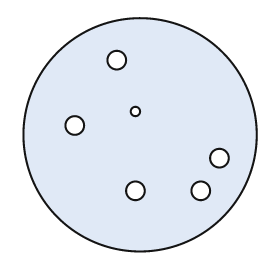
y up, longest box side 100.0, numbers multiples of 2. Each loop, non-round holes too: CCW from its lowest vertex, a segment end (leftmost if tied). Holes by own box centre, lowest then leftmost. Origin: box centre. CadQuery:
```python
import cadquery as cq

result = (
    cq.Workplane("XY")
    .moveTo(0.0, 0.0)
    .circle(50.0)
    .moveTo(-2.0, -24.0)
    .circle(4.0)
    .moveTo(26.0, -24.0)
    .circle(4.0)
    .moveTo(34.0, -10.0)
    .circle(4.0)
    .moveTo(-28.0, 4.0)
    .circle(4.0)
    .moveTo(-2.0, 10.0)
    .circle(2.0)
    .moveTo(-10.0, 32.0)
    .circle(4.0)
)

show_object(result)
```